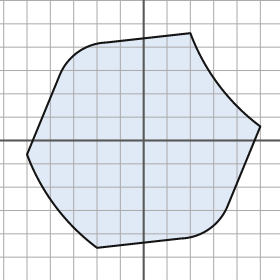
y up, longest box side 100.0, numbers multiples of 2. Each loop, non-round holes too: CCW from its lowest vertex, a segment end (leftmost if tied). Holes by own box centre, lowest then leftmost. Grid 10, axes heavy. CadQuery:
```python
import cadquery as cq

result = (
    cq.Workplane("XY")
    .moveTo(-20.0, -46.0)
    .lineTo(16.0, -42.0)
    .threePointArc((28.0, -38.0), (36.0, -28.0))
    .lineTo(50.0, 6.0)
    .threePointArc((32.0, 24.0), (20.0, 46.0))
    .lineTo(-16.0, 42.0)
    .threePointArc((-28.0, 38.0), (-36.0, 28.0))
    .lineTo(-50.0, -6.0)
    .threePointArc((-38.0, -28.0), (-20.0, -46.0))
    .close()
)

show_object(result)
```